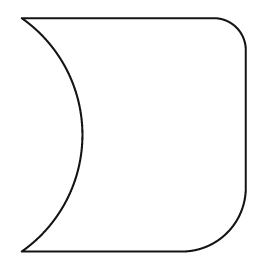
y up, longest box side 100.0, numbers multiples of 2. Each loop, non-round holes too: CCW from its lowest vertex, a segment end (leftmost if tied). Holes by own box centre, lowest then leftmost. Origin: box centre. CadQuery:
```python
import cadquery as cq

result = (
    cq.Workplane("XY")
    .moveTo(-48.0, -50.0)
    .lineTo(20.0, -50.0)
    .threePointArc((40.0, -42.0), (48.0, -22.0))
    .lineTo(48.0, 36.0)
    .threePointArc((44.0, 46.0), (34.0, 50.0))
    .lineTo(-48.0, 50.0)
    .threePointArc((-22.0, 0.0), (-48.0, -50.0))
    .close()
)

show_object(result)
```